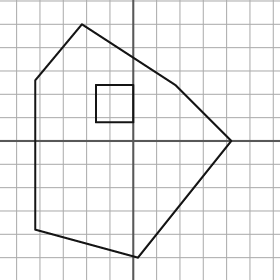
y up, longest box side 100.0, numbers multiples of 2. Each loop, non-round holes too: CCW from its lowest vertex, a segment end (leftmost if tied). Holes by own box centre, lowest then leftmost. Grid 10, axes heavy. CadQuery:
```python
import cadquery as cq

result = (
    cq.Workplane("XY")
    .moveTo(2.0, -50.0)
    .lineTo(42.0, 0.0)
    .lineTo(18.0, 24.0)
    .lineTo(-22.0, 50.0)
    .lineTo(-42.0, 26.0)
    .lineTo(-42.0, -38.0)
    .close()
    .moveTo(-16.0, 8.0)
    .lineTo(0.0, 8.0)
    .lineTo(0.0, 24.0)
    .lineTo(-16.0, 24.0)
    .close()
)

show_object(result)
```